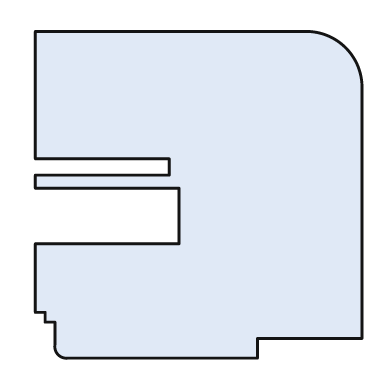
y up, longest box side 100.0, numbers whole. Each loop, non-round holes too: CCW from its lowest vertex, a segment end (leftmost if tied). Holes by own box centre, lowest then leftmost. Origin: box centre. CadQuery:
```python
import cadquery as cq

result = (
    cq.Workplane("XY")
    .moveTo(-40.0, -50.0)
    .lineTo(18.0, -50.0)
    .lineTo(18.0, -44.0)
    .lineTo(50.0, -44.0)
    .lineTo(50.0, 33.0)
    .threePointArc((45.0, 45.0), (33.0, 50.0))
    .lineTo(-50.0, 50.0)
    .lineTo(-50.0, 11.0)
    .lineTo(-9.0, 11.0)
    .lineTo(-9.0, 6.0)
    .lineTo(-50.0, 6.0)
    .lineTo(-50.0, 2.0)
    .lineTo(-6.0, 2.0)
    .lineTo(-6.0, -15.0)
    .lineTo(-50.0, -15.0)
    .lineTo(-50.0, -36.0)
    .lineTo(-47.0, -36.0)
    .lineTo(-47.0, -39.0)
    .lineTo(-44.0, -39.0)
    .lineTo(-44.0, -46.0)
    .threePointArc((-43.0, -49.0), (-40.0, -50.0))
    .close()
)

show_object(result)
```